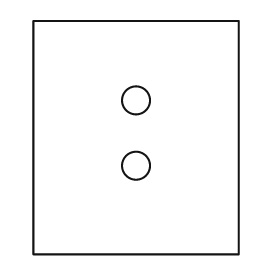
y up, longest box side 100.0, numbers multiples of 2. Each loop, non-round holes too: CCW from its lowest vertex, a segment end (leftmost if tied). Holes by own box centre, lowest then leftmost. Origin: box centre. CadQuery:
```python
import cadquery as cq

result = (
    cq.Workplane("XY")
    .moveTo(-44.0, -50.0)
    .lineTo(44.0, -50.0)
    .lineTo(44.0, 50.0)
    .lineTo(-44.0, 50.0)
    .close()
    .moveTo(0.0, -12.0)
    .circle(6.0)
    .moveTo(0.0, 16.0)
    .circle(6.0)
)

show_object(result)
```